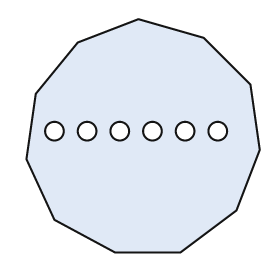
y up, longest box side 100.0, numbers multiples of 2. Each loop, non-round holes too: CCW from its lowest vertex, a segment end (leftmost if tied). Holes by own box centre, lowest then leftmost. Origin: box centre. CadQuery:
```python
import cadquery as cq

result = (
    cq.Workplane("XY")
    .moveTo(-12.0, -50.0)
    .lineTo(16.0, -50.0)
    .lineTo(40.0, -32.0)
    .lineTo(50.0, -6.0)
    .lineTo(46.0, 22.0)
    .lineTo(26.0, 42.0)
    .lineTo(-2.0, 50.0)
    .lineTo(-28.0, 40.0)
    .lineTo(-46.0, 18.0)
    .lineTo(-50.0, -10.0)
    .lineTo(-38.0, -36.0)
    .close()
    .moveTo(-38.0, 2.0)
    .circle(4.0)
    .moveTo(-24.0, 2.0)
    .circle(4.0)
    .moveTo(-10.0, 2.0)
    .circle(4.0)
    .moveTo(4.0, 2.0)
    .circle(4.0)
    .moveTo(18.0, 2.0)
    .circle(4.0)
    .moveTo(32.0, 2.0)
    .circle(4.0)
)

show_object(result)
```